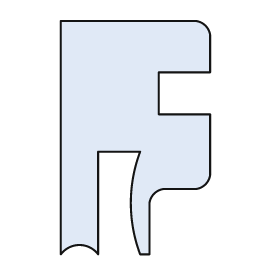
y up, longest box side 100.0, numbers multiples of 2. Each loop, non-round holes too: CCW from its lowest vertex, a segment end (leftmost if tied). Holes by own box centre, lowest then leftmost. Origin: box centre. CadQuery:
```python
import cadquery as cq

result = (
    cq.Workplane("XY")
    .moveTo(-32.0, -50.0)
    .threePointArc((-24.0, -46.0), (-16.0, -50.0))
    .lineTo(-16.0, -6.0)
    .lineTo(2.0, -6.0)
    .threePointArc((-2.0, -28.0), (2.0, -50.0))
    .lineTo(6.0, -50.0)
    .lineTo(6.0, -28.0)
    .threePointArc((8.0, -24.0), (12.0, -22.0))
    .lineTo(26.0, -22.0)
    .threePointArc((30.0, -20.0), (32.0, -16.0))
    .lineTo(32.0, 10.0)
    .lineTo(10.0, 10.0)
    .lineTo(10.0, 28.0)
    .lineTo(32.0, 28.0)
    .lineTo(32.0, 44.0)
    .threePointArc((30.0, 48.0), (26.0, 50.0))
    .lineTo(-32.0, 50.0)
    .close()
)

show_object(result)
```